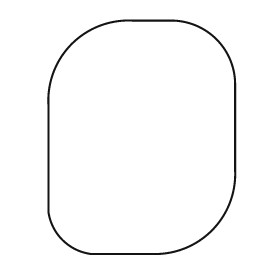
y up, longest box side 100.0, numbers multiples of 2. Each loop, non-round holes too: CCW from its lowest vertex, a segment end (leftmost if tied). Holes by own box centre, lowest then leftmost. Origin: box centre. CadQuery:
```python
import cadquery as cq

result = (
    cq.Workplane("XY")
    .moveTo(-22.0, -50.0)
    .lineTo(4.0, -50.0)
    .threePointArc((30.0, -40.0), (40.0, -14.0))
    .lineTo(40.0, 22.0)
    .threePointArc((32.0, 42.0), (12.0, 50.0))
    .lineTo(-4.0, 50.0)
    .threePointArc((-30.0, 40.0), (-40.0, 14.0))
    .lineTo(-40.0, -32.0)
    .threePointArc((-34.0, -44.0), (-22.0, -50.0))
    .close()
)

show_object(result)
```